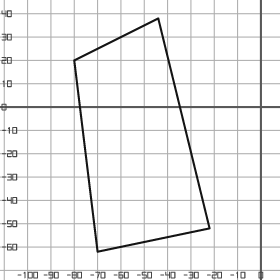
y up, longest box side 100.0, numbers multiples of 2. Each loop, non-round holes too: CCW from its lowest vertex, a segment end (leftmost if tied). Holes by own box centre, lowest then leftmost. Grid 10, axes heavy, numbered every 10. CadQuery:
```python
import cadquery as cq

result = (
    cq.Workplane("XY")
    .moveTo(-70.0, -62.0)
    .lineTo(-22.0, -52.0)
    .lineTo(-44.0, 38.0)
    .lineTo(-80.0, 20.0)
    .close()
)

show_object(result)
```